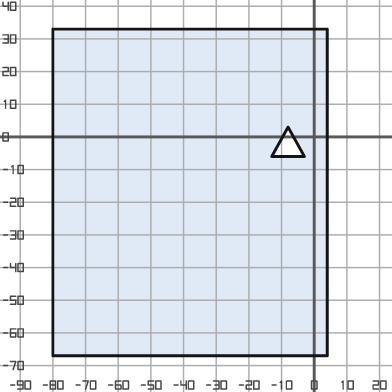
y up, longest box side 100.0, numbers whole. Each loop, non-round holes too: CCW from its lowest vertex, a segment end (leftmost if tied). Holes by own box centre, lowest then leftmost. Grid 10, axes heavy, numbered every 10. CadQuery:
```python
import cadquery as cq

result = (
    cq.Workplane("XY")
    .moveTo(-80.0, -67.0)
    .lineTo(4.0, -67.0)
    .lineTo(4.0, 33.0)
    .lineTo(-80.0, 33.0)
    .close()
    .moveTo(-13.0, -6.0)
    .lineTo(-3.0, -6.0)
    .lineTo(-8.0, 3.0)
    .close()
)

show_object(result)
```